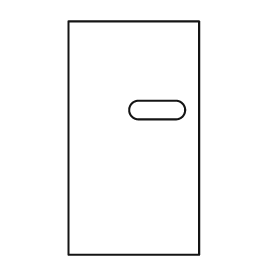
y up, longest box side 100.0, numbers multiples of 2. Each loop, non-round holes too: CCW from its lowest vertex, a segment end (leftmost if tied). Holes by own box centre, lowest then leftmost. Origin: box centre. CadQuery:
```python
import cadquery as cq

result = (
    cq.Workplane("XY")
    .moveTo(-28.0, -50.0)
    .lineTo(28.0, -50.0)
    .lineTo(28.0, 50.0)
    .lineTo(-28.0, 50.0)
    .close()
    .moveTo(2.0, 8.0)
    .lineTo(18.0, 8.0)
    .threePointArc((22.0, 12.0), (18.0, 16.0))
    .lineTo(2.0, 16.0)
    .threePointArc((-2.0, 12.0), (2.0, 8.0))
    .close()
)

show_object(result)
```